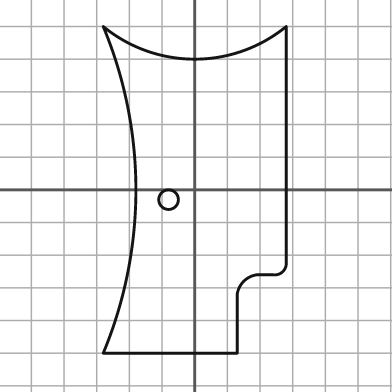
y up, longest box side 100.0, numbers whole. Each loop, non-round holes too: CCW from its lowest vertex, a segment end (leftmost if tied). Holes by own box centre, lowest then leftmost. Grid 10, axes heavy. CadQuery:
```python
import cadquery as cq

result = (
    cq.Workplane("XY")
    .moveTo(-28.0, -50.0)
    .lineTo(13.0, -50.0)
    .lineTo(13.0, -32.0)
    .threePointArc((15.0, -28.0), (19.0, -26.0))
    .lineTo(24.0, -26.0)
    .threePointArc((27.0, -25.0), (28.0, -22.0))
    .lineTo(28.0, 50.0)
    .threePointArc((0.0, 40.0), (-28.0, 50.0))
    .threePointArc((-18.0, 0.0), (-28.0, -50.0))
    .close()
    .moveTo(-8.0, -3.0)
    .circle(3.0)
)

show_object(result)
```